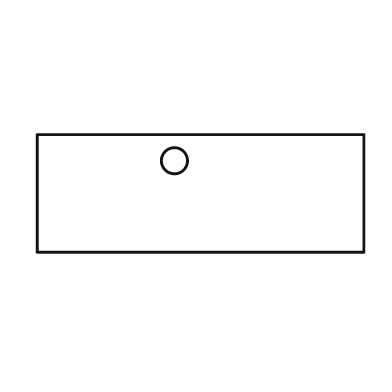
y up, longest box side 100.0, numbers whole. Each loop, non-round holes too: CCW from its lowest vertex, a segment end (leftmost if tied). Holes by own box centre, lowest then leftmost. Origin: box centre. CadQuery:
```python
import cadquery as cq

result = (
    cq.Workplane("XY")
    .moveTo(-50.0, -18.0)
    .lineTo(50.0, -18.0)
    .lineTo(50.0, 18.0)
    .lineTo(-50.0, 18.0)
    .close()
    .moveTo(-8.0, 10.0)
    .circle(4.0)
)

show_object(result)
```